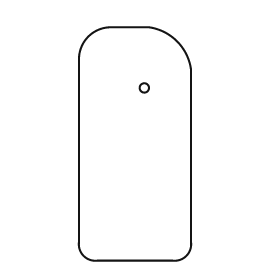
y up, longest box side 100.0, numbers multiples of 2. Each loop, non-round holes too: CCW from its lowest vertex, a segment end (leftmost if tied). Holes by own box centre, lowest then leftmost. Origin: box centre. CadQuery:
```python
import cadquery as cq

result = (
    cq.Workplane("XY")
    .moveTo(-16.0, -50.0)
    .lineTo(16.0, -50.0)
    .threePointArc((22.0, -48.0), (24.0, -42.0))
    .lineTo(24.0, 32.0)
    .threePointArc((18.0, 44.0), (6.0, 50.0))
    .lineTo(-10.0, 50.0)
    .threePointArc((-20.0, 46.0), (-24.0, 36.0))
    .lineTo(-24.0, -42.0)
    .threePointArc((-22.0, -48.0), (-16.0, -50.0))
    .close()
    .moveTo(4.0, 24.0)
    .circle(2.0)
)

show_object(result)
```